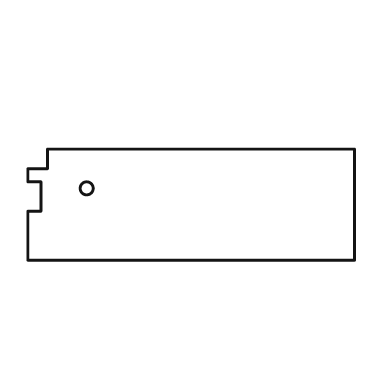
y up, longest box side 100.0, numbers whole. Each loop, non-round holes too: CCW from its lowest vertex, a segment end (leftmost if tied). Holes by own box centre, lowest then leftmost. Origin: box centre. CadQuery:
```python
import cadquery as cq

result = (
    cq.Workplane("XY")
    .moveTo(-50.0, -17.0)
    .lineTo(50.0, -17.0)
    .lineTo(50.0, 17.0)
    .lineTo(-44.0, 17.0)
    .lineTo(-44.0, 11.0)
    .lineTo(-50.0, 11.0)
    .lineTo(-50.0, 7.0)
    .lineTo(-46.0, 7.0)
    .lineTo(-46.0, -2.0)
    .lineTo(-50.0, -2.0)
    .close()
    .moveTo(-32.0, 5.0)
    .circle(2.0)
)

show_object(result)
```